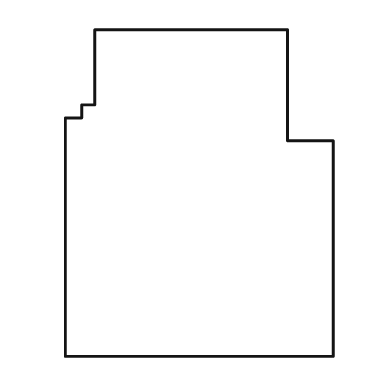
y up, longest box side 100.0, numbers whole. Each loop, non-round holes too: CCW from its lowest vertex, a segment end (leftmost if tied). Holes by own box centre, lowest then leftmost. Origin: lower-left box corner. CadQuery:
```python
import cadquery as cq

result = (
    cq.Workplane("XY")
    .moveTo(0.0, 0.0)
    .lineTo(82.0, 0.0)
    .lineTo(82.0, 66.0)
    .lineTo(68.0, 66.0)
    .lineTo(68.0, 100.0)
    .lineTo(9.0, 100.0)
    .lineTo(9.0, 77.0)
    .lineTo(5.0, 77.0)
    .lineTo(5.0, 73.0)
    .lineTo(0.0, 73.0)
    .close()
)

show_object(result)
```